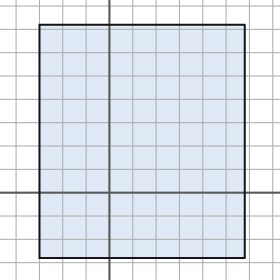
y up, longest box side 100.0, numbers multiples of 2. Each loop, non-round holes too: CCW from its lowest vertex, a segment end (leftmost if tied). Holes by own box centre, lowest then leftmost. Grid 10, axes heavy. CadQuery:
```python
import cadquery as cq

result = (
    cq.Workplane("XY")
    .moveTo(-30.0, -28.0)
    .lineTo(58.0, -28.0)
    .lineTo(58.0, 72.0)
    .lineTo(-30.0, 72.0)
    .close()
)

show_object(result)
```